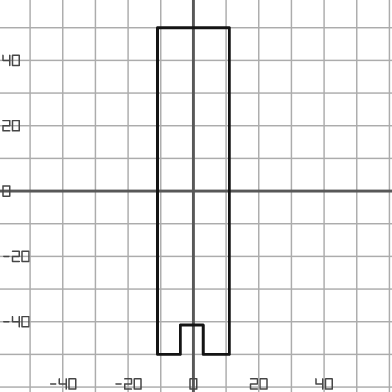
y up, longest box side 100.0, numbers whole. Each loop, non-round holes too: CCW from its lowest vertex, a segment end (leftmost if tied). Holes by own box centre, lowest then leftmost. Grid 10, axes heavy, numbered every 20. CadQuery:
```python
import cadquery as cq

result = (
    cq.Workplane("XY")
    .moveTo(-11.0, -50.0)
    .lineTo(-4.0, -50.0)
    .lineTo(-4.0, -41.0)
    .lineTo(3.0, -41.0)
    .lineTo(3.0, -50.0)
    .lineTo(11.0, -50.0)
    .lineTo(11.0, 50.0)
    .lineTo(-11.0, 50.0)
    .close()
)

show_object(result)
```